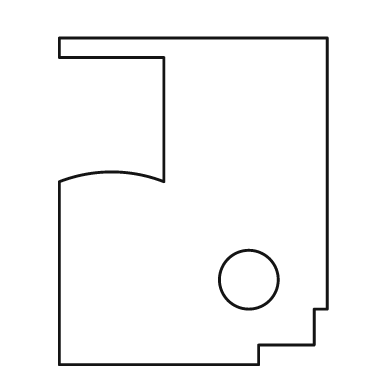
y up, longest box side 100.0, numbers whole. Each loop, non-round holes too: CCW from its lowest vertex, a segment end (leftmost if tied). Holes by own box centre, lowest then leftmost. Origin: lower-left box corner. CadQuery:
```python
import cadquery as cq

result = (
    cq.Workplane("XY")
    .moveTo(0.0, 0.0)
    .lineTo(61.0, 0.0)
    .lineTo(61.0, 6.0)
    .lineTo(78.0, 6.0)
    .lineTo(78.0, 17.0)
    .lineTo(82.0, 17.0)
    .lineTo(82.0, 100.0)
    .lineTo(0.0, 100.0)
    .lineTo(0.0, 94.0)
    .lineTo(32.0, 94.0)
    .lineTo(32.0, 56.0)
    .threePointArc((16.0, 59.0), (0.0, 56.0))
    .close()
    .moveTo(58.0, 26.0)
    .circle(9.0)
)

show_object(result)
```